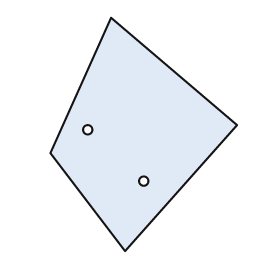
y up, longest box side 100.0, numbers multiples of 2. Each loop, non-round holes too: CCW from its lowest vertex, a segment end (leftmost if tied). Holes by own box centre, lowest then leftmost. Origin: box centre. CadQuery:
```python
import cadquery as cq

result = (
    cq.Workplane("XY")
    .moveTo(-8.0, -50.0)
    .lineTo(40.0, 4.0)
    .lineTo(-14.0, 50.0)
    .lineTo(-40.0, -8.0)
    .close()
    .moveTo(0.0, -20.0)
    .circle(2.0)
    .moveTo(-24.0, 2.0)
    .circle(2.0)
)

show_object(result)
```